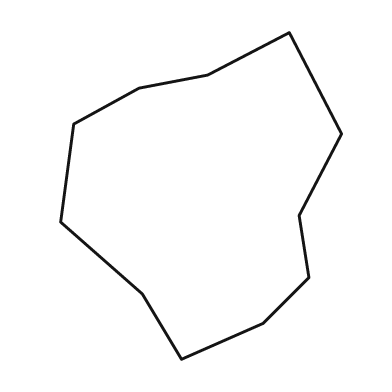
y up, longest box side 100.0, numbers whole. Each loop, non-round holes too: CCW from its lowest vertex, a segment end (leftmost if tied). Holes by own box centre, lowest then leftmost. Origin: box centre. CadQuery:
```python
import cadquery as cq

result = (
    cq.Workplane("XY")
    .moveTo(-6.0, -50.0)
    .lineTo(19.0, -39.0)
    .lineTo(33.0, -25.0)
    .lineTo(30.0, -6.0)
    .lineTo(43.0, 19.0)
    .lineTo(27.0, 50.0)
    .lineTo(2.0, 37.0)
    .lineTo(-19.0, 33.0)
    .lineTo(-39.0, 22.0)
    .lineTo(-43.0, -8.0)
    .lineTo(-18.0, -30.0)
    .close()
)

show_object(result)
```